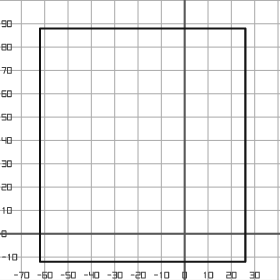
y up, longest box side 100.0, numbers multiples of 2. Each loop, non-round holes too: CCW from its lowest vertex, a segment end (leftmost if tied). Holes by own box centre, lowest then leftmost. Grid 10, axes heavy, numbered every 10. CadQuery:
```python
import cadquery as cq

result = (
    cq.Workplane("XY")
    .moveTo(-62.0, -12.0)
    .lineTo(26.0, -12.0)
    .lineTo(26.0, 88.0)
    .lineTo(-62.0, 88.0)
    .close()
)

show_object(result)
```